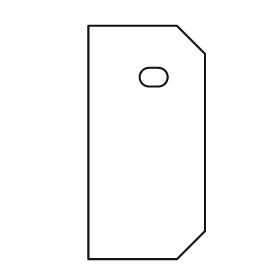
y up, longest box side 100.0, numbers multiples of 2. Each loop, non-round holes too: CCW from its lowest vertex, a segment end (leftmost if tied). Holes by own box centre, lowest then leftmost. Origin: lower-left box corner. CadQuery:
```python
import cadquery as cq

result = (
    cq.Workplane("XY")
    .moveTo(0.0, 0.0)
    .lineTo(38.0, 0.0)
    .lineTo(50.0, 12.0)
    .lineTo(50.0, 88.0)
    .lineTo(38.0, 100.0)
    .lineTo(0.0, 100.0)
    .close()
    .moveTo(26.0, 74.0)
    .lineTo(30.0, 74.0)
    .threePointArc((34.0, 78.0), (30.0, 82.0))
    .lineTo(26.0, 82.0)
    .threePointArc((22.0, 78.0), (26.0, 74.0))
    .close()
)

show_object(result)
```